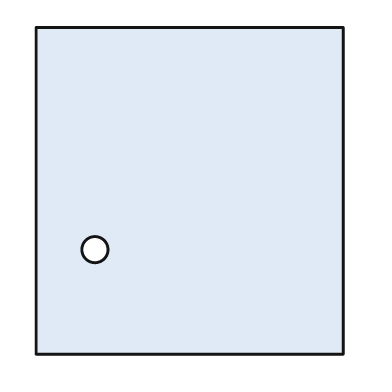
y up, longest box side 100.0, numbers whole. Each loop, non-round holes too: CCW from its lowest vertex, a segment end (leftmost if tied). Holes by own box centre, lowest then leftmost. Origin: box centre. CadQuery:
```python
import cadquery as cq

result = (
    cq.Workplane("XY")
    .moveTo(-47.0, -50.0)
    .lineTo(47.0, -50.0)
    .lineTo(47.0, 50.0)
    .lineTo(-47.0, 50.0)
    .close()
    .moveTo(-29.0, -18.0)
    .circle(4.0)
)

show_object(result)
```